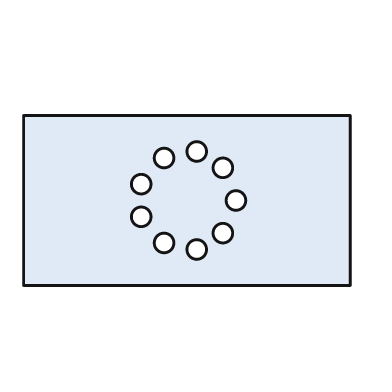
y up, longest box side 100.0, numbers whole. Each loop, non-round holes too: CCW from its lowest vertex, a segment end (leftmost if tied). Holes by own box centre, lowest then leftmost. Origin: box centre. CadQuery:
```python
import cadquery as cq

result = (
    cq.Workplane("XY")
    .moveTo(-50.0, -26.0)
    .lineTo(50.0, -26.0)
    .lineTo(50.0, 26.0)
    .lineTo(-50.0, 26.0)
    .close()
    .moveTo(3.0, -15.0)
    .circle(3.0)
    .moveTo(-7.0, -13.0)
    .circle(3.0)
    .moveTo(11.0, -10.0)
    .circle(3.0)
    .moveTo(-14.0, -5.0)
    .circle(3.0)
    .moveTo(15.0, 0.0)
    .circle(3.0)
    .moveTo(-14.0, 5.0)
    .circle(3.0)
    .moveTo(11.0, 10.0)
    .circle(3.0)
    .moveTo(-7.0, 13.0)
    .circle(3.0)
    .moveTo(3.0, 15.0)
    .circle(3.0)
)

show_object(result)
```